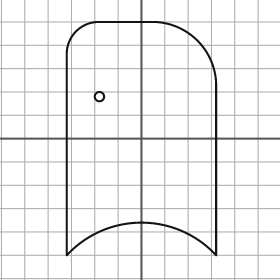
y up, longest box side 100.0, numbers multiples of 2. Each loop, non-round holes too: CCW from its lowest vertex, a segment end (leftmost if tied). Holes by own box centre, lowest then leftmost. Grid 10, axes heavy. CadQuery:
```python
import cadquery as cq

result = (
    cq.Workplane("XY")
    .moveTo(-32.0, -50.0)
    .threePointArc((0.0, -36.0), (32.0, -50.0))
    .lineTo(32.0, 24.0)
    .threePointArc((24.0, 42.0), (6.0, 50.0))
    .lineTo(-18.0, 50.0)
    .threePointArc((-28.0, 46.0), (-32.0, 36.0))
    .close()
    .moveTo(-18.0, 18.0)
    .circle(2.0)
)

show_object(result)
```